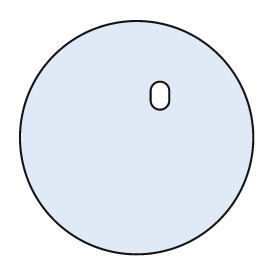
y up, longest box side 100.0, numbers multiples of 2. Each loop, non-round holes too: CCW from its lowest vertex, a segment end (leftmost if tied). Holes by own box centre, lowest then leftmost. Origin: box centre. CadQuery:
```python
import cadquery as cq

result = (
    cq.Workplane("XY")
    .moveTo(0.0, 0.0)
    .circle(50.0)
    .moveTo(6.0, 16.0)
    .threePointArc((10.0, 12.0), (14.0, 16.0))
    .lineTo(14.0, 20.0)
    .threePointArc((10.0, 24.0), (6.0, 20.0))
    .close()
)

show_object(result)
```